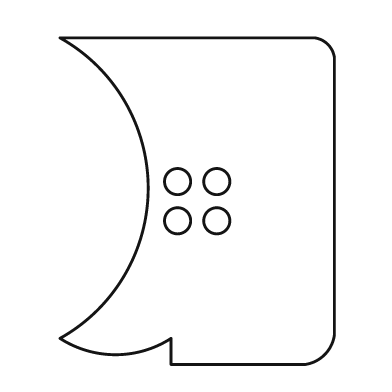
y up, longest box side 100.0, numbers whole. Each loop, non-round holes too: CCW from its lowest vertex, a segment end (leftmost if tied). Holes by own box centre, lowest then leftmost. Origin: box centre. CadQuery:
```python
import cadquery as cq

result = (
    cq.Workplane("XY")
    .moveTo(-8.0, -50.0)
    .lineTo(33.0, -50.0)
    .threePointArc((39.0, -47.0), (42.0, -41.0))
    .lineTo(42.0, 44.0)
    .threePointArc((40.0, 48.0), (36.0, 50.0))
    .lineTo(-42.0, 50.0)
    .threePointArc((-15.0, 4.0), (-42.0, -42.0))
    .threePointArc((-25.0, -47.0), (-8.0, -42.0))
    .close()
    .moveTo(-6.0, -6.0)
    .circle(4.0)
    .moveTo(6.0, -6.0)
    .circle(4.0)
    .moveTo(-6.0, 6.0)
    .circle(4.0)
    .moveTo(6.0, 6.0)
    .circle(4.0)
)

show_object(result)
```